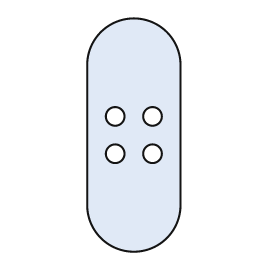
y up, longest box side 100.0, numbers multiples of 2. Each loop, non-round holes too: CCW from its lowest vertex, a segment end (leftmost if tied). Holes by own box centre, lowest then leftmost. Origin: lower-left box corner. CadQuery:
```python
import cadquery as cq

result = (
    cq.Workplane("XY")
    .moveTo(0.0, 20.0)
    .threePointArc((20.0, 0.0), (40.0, 20.0))
    .lineTo(40.0, 80.0)
    .threePointArc((20.0, 100.0), (0.0, 80.0))
    .close()
    .moveTo(12.0, 42.0)
    .circle(4.0)
    .moveTo(28.0, 42.0)
    .circle(4.0)
    .moveTo(12.0, 58.0)
    .circle(4.0)
    .moveTo(28.0, 58.0)
    .circle(4.0)
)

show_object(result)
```